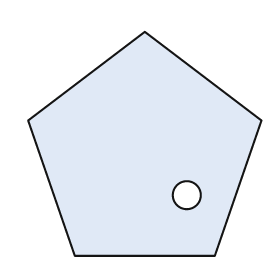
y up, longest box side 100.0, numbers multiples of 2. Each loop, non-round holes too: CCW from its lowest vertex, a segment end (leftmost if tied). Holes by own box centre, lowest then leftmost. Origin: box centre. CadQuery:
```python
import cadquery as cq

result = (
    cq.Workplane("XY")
    .moveTo(-30.0, -48.0)
    .lineTo(30.0, -48.0)
    .lineTo(50.0, 10.0)
    .lineTo(0.0, 48.0)
    .lineTo(-50.0, 10.0)
    .close()
    .moveTo(18.0, -22.0)
    .circle(6.0)
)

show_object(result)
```